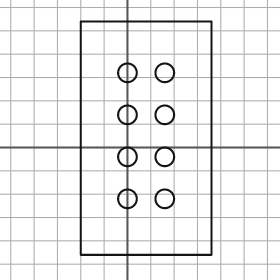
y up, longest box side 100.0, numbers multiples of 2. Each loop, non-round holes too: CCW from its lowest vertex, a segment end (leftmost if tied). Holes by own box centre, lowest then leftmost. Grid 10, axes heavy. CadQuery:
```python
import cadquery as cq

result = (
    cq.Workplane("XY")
    .moveTo(-20.0, -46.0)
    .lineTo(36.0, -46.0)
    .lineTo(36.0, 54.0)
    .lineTo(-20.0, 54.0)
    .close()
    .moveTo(0.0, -22.0)
    .circle(4.0)
    .moveTo(16.0, -22.0)
    .circle(4.0)
    .moveTo(0.0, -4.0)
    .circle(4.0)
    .moveTo(16.0, -4.0)
    .circle(4.0)
    .moveTo(0.0, 14.0)
    .circle(4.0)
    .moveTo(16.0, 14.0)
    .circle(4.0)
    .moveTo(0.0, 32.0)
    .circle(4.0)
    .moveTo(16.0, 32.0)
    .circle(4.0)
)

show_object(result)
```